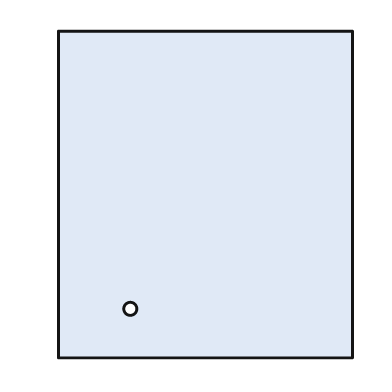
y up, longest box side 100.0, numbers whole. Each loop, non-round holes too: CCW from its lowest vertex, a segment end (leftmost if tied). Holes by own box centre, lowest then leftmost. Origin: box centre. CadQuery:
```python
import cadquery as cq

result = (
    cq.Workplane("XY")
    .moveTo(-45.0, -50.0)
    .lineTo(45.0, -50.0)
    .lineTo(45.0, 50.0)
    .lineTo(-45.0, 50.0)
    .close()
    .moveTo(-23.0, -35.0)
    .circle(2.0)
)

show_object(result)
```